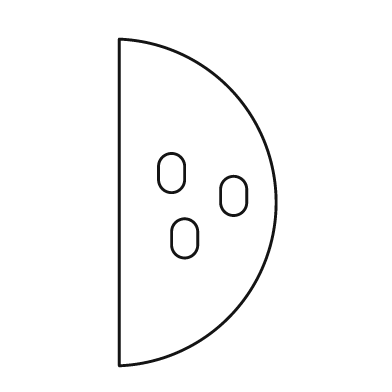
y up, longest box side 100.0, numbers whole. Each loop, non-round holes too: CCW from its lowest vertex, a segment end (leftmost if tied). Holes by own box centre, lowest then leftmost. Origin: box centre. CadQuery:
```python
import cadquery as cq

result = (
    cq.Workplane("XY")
    .moveTo(-24.0, -50.0)
    .threePointArc((24.0, 0.0), (-24.0, 50.0))
    .close()
    .moveTo(-8.0, -13.0)
    .threePointArc((-4.0, -17.0), (0.0, -13.0))
    .lineTo(0.0, -9.0)
    .threePointArc((-4.0, -5.0), (-8.0, -9.0))
    .close()
    .moveTo(7.0, 0.0)
    .threePointArc((11.0, -4.0), (15.0, 0.0))
    .lineTo(15.0, 4.0)
    .threePointArc((11.0, 8.0), (7.0, 4.0))
    .close()
    .moveTo(-12.0, 7.0)
    .threePointArc((-8.0, 3.0), (-4.0, 7.0))
    .lineTo(-4.0, 11.0)
    .threePointArc((-8.0, 15.0), (-12.0, 11.0))
    .close()
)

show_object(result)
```